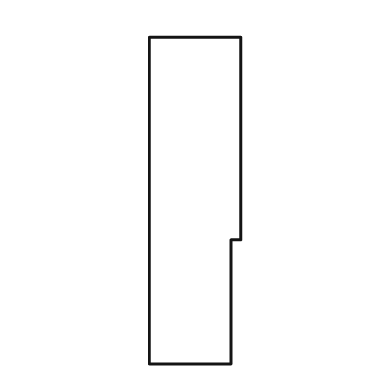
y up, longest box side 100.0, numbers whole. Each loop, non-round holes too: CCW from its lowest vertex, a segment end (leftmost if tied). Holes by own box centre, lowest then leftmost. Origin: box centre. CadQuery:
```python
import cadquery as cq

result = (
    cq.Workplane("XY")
    .moveTo(-14.0, -50.0)
    .lineTo(11.0, -50.0)
    .lineTo(11.0, -12.0)
    .lineTo(14.0, -12.0)
    .lineTo(14.0, 50.0)
    .lineTo(-14.0, 50.0)
    .close()
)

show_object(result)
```